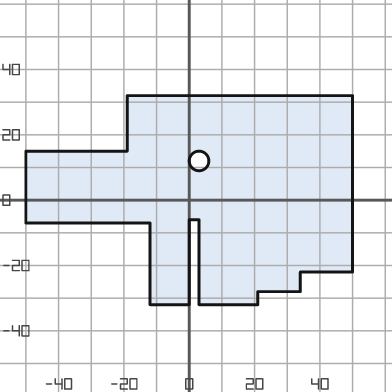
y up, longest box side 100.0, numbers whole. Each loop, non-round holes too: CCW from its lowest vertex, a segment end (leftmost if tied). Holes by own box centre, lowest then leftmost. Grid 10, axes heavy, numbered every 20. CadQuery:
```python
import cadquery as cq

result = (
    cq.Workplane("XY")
    .moveTo(-12.0, -32.0)
    .lineTo(0.0, -32.0)
    .lineTo(0.0, -6.0)
    .lineTo(3.0, -6.0)
    .lineTo(3.0, -32.0)
    .lineTo(21.0, -32.0)
    .lineTo(21.0, -28.0)
    .lineTo(34.0, -28.0)
    .lineTo(34.0, -22.0)
    .lineTo(50.0, -22.0)
    .lineTo(50.0, 32.0)
    .lineTo(-19.0, 32.0)
    .lineTo(-19.0, 15.0)
    .lineTo(-50.0, 15.0)
    .lineTo(-50.0, -7.0)
    .lineTo(-12.0, -7.0)
    .close()
    .moveTo(3.0, 12.0)
    .circle(3.0)
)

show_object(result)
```